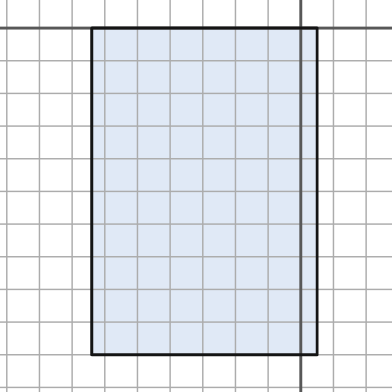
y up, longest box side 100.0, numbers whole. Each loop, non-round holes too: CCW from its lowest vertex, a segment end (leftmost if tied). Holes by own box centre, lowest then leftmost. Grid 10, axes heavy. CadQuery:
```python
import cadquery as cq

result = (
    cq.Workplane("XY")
    .moveTo(-64.0, -100.0)
    .lineTo(5.0, -100.0)
    .lineTo(5.0, 0.0)
    .lineTo(-64.0, 0.0)
    .close()
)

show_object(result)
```